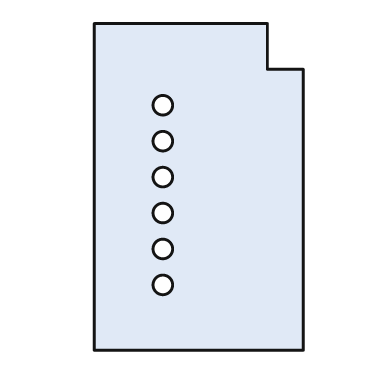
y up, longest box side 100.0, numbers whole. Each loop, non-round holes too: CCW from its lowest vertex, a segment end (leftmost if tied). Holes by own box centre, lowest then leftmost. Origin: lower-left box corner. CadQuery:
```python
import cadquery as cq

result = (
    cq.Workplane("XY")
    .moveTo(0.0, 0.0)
    .lineTo(64.0, 0.0)
    .lineTo(64.0, 86.0)
    .lineTo(53.0, 86.0)
    .lineTo(53.0, 100.0)
    .lineTo(0.0, 100.0)
    .close()
    .moveTo(21.0, 20.0)
    .circle(3.0)
    .moveTo(21.0, 31.0)
    .circle(3.0)
    .moveTo(21.0, 42.0)
    .circle(3.0)
    .moveTo(21.0, 53.0)
    .circle(3.0)
    .moveTo(21.0, 64.0)
    .circle(3.0)
    .moveTo(21.0, 75.0)
    .circle(3.0)
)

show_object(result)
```